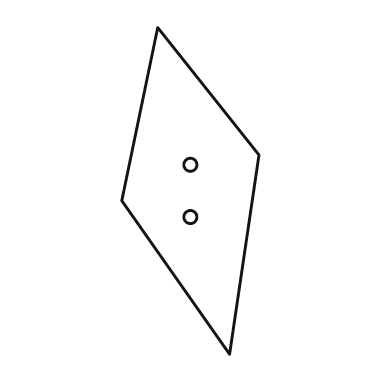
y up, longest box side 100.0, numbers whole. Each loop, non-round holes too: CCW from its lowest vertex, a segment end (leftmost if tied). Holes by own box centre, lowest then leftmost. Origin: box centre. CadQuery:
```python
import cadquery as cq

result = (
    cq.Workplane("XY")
    .moveTo(12.0, -50.0)
    .lineTo(21.0, 11.0)
    .lineTo(-10.0, 50.0)
    .lineTo(-21.0, -3.0)
    .close()
    .moveTo(0.0, -8.0)
    .circle(2.0)
    .moveTo(0.0, 8.0)
    .circle(2.0)
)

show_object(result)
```